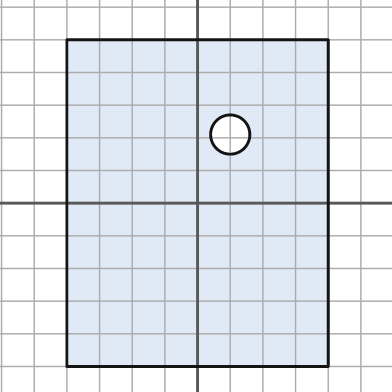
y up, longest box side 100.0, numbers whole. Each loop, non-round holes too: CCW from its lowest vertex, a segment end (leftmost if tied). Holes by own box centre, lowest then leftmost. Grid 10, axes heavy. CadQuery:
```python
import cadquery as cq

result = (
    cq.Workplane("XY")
    .moveTo(-40.0, -50.0)
    .lineTo(40.0, -50.0)
    .lineTo(40.0, 50.0)
    .lineTo(-40.0, 50.0)
    .close()
    .moveTo(10.0, 21.0)
    .circle(6.0)
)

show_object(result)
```